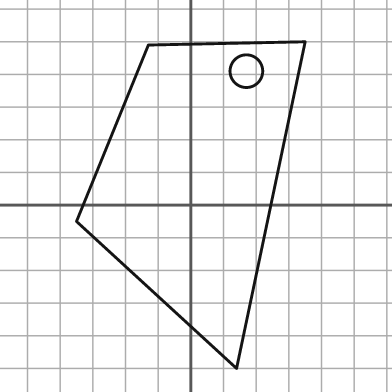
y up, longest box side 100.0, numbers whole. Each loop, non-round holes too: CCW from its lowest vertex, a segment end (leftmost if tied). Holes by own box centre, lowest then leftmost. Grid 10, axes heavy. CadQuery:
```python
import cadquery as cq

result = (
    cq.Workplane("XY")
    .moveTo(14.0, -50.0)
    .lineTo(35.0, 50.0)
    .lineTo(-13.0, 49.0)
    .lineTo(-35.0, -5.0)
    .close()
    .moveTo(17.0, 41.0)
    .circle(5.0)
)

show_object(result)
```